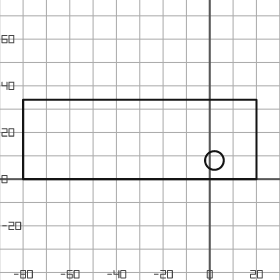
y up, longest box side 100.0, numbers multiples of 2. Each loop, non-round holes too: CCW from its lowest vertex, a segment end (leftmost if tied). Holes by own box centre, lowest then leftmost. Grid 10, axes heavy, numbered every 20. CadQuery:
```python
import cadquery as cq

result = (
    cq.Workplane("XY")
    .moveTo(-80.0, 0.0)
    .lineTo(20.0, 0.0)
    .lineTo(20.0, 34.0)
    .lineTo(-80.0, 34.0)
    .close()
    .moveTo(2.0, 8.0)
    .circle(4.0)
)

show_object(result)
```